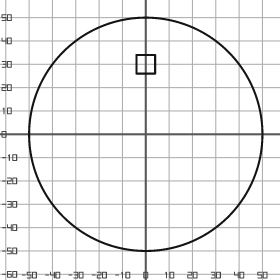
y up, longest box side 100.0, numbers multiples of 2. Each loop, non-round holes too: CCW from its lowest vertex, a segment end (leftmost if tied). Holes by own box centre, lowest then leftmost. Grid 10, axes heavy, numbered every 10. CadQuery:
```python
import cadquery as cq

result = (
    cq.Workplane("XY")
    .moveTo(0.0, 0.0)
    .circle(50.0)
    .moveTo(-4.0, 26.0)
    .lineTo(4.0, 26.0)
    .lineTo(4.0, 34.0)
    .lineTo(-4.0, 34.0)
    .close()
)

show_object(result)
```